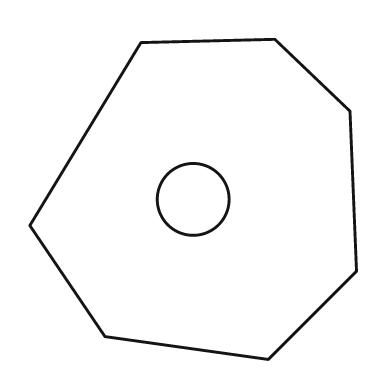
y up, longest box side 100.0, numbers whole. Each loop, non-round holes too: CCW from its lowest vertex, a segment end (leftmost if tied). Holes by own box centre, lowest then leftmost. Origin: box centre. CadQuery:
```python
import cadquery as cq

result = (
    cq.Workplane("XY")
    .moveTo(23.0, -49.0)
    .lineTo(50.0, -22.0)
    .lineTo(48.0, 27.0)
    .lineTo(25.0, 49.0)
    .lineTo(-16.0, 48.0)
    .lineTo(-50.0, -8.0)
    .lineTo(-27.0, -42.0)
    .close()
    .moveTo(0.0, 0.0)
    .circle(11.0)
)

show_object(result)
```